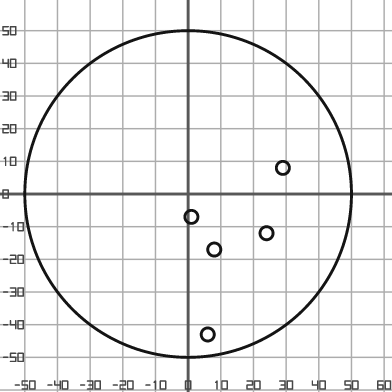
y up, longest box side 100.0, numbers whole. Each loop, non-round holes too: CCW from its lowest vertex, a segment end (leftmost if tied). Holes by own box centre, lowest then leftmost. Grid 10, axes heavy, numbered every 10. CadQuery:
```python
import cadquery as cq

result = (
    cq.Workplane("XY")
    .moveTo(0.0, 0.0)
    .circle(50.0)
    .moveTo(6.0, -43.0)
    .circle(2.0)
    .moveTo(8.0, -17.0)
    .circle(2.0)
    .moveTo(24.0, -12.0)
    .circle(2.0)
    .moveTo(1.0, -7.0)
    .circle(2.0)
    .moveTo(29.0, 8.0)
    .circle(2.0)
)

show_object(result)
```